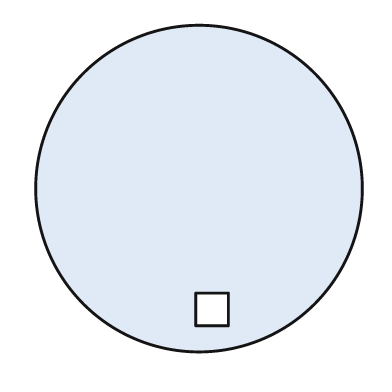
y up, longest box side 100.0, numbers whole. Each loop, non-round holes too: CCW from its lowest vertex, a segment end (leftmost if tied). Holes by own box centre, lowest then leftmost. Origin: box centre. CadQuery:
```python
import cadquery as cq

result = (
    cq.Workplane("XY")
    .moveTo(0.0, 0.0)
    .circle(50.0)
    .moveTo(-1.0, -42.0)
    .lineTo(9.0, -42.0)
    .lineTo(9.0, -32.0)
    .lineTo(-1.0, -32.0)
    .close()
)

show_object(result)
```